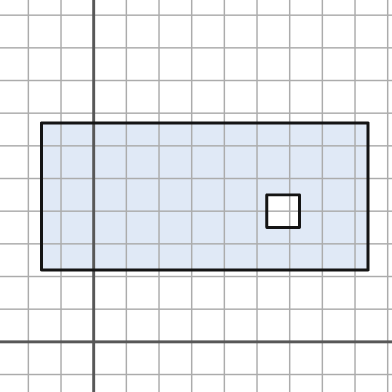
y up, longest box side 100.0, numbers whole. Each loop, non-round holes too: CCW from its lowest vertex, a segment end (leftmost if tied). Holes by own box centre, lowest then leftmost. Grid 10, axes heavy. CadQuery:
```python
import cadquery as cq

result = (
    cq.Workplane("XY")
    .moveTo(-16.0, 22.0)
    .lineTo(84.0, 22.0)
    .lineTo(84.0, 67.0)
    .lineTo(-16.0, 67.0)
    .close()
    .moveTo(53.0, 35.0)
    .lineTo(63.0, 35.0)
    .lineTo(63.0, 45.0)
    .lineTo(53.0, 45.0)
    .close()
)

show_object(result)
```